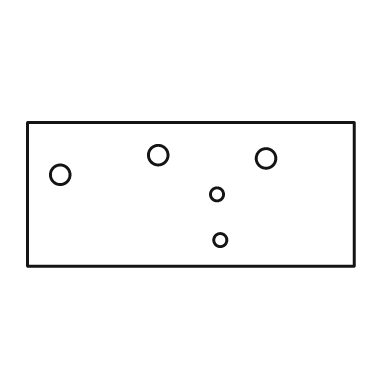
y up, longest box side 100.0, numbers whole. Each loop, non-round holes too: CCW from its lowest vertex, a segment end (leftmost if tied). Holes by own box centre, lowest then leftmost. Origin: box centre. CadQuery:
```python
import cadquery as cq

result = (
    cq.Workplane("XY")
    .moveTo(-50.0, -22.0)
    .lineTo(50.0, -22.0)
    .lineTo(50.0, 22.0)
    .lineTo(-50.0, 22.0)
    .close()
    .moveTo(9.0, -14.0)
    .circle(2.0)
    .moveTo(8.0, 0.0)
    .circle(2.0)
    .moveTo(-40.0, 6.0)
    .circle(3.0)
    .moveTo(23.0, 11.0)
    .circle(3.0)
    .moveTo(-10.0, 12.0)
    .circle(3.0)
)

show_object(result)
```